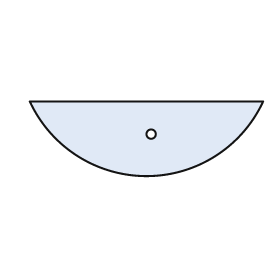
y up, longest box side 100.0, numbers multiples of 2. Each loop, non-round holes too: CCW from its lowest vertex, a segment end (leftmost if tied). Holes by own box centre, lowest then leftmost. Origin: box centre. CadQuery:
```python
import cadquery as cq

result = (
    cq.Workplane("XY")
    .moveTo(-50.0, 16.0)
    .threePointArc((0.0, -16.0), (50.0, 16.0))
    .close()
    .moveTo(2.0, 2.0)
    .circle(2.0)
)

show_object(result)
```